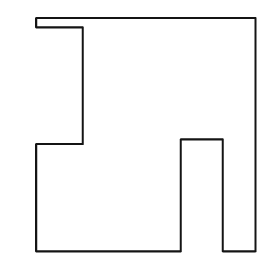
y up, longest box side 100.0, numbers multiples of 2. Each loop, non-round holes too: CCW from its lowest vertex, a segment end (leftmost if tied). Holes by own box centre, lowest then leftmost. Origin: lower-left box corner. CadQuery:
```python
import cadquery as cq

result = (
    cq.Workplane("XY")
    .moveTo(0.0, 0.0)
    .lineTo(62.0, 0.0)
    .lineTo(62.0, 48.0)
    .lineTo(80.0, 48.0)
    .lineTo(80.0, 0.0)
    .lineTo(94.0, 0.0)
    .lineTo(94.0, 100.0)
    .lineTo(0.0, 100.0)
    .lineTo(0.0, 96.0)
    .lineTo(20.0, 96.0)
    .lineTo(20.0, 46.0)
    .lineTo(0.0, 46.0)
    .close()
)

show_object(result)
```